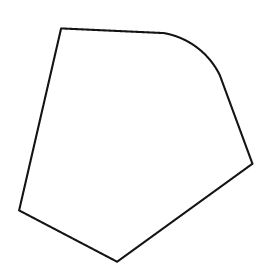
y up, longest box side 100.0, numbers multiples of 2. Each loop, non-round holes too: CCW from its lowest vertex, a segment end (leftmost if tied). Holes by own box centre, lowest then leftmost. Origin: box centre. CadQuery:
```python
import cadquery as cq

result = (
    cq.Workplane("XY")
    .moveTo(-8.0, -50.0)
    .lineTo(50.0, -8.0)
    .lineTo(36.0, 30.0)
    .threePointArc((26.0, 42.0), (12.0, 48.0))
    .lineTo(-32.0, 50.0)
    .lineTo(-50.0, -28.0)
    .close()
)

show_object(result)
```